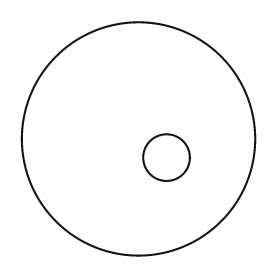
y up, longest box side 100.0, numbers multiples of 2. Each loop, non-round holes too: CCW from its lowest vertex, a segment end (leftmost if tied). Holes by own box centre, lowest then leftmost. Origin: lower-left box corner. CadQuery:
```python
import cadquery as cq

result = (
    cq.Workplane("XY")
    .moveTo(50.0, 50.0)
    .circle(50.0)
    .moveTo(62.0, 42.0)
    .circle(10.0)
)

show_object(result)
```